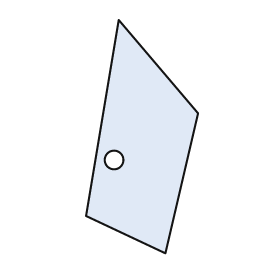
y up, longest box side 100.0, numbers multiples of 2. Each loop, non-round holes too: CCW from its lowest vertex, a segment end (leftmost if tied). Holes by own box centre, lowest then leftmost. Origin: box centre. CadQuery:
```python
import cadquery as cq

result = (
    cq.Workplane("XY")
    .moveTo(10.0, -50.0)
    .lineTo(24.0, 10.0)
    .lineTo(-10.0, 50.0)
    .lineTo(-24.0, -34.0)
    .close()
    .moveTo(-12.0, -10.0)
    .circle(4.0)
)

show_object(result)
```